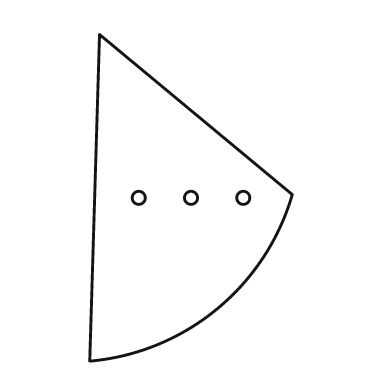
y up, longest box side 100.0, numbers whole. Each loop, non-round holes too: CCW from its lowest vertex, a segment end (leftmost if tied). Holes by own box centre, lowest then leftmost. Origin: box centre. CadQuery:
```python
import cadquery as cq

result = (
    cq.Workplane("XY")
    .moveTo(-31.0, -50.0)
    .threePointArc((8.0, -34.0), (31.0, 1.0))
    .lineTo(-28.0, 50.0)
    .close()
    .moveTo(-16.0, 0.0)
    .circle(2.0)
    .moveTo(0.0, 0.0)
    .circle(2.0)
    .moveTo(16.0, 0.0)
    .circle(2.0)
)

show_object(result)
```